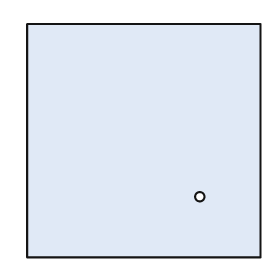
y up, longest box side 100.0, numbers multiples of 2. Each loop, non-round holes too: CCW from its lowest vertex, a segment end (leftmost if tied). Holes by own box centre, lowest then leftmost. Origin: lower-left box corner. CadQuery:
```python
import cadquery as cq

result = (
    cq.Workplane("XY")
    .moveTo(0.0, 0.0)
    .lineTo(100.0, 0.0)
    .lineTo(100.0, 100.0)
    .lineTo(0.0, 100.0)
    .close()
    .moveTo(74.0, 26.0)
    .circle(2.0)
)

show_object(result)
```